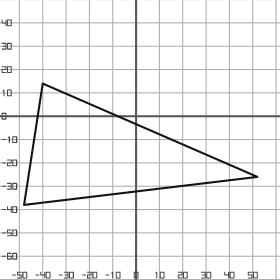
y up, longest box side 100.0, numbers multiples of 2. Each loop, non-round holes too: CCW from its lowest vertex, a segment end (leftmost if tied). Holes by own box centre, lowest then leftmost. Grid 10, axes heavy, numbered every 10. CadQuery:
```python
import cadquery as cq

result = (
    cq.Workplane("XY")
    .moveTo(-48.0, -38.0)
    .lineTo(52.0, -26.0)
    .lineTo(-40.0, 14.0)
    .close()
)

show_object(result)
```